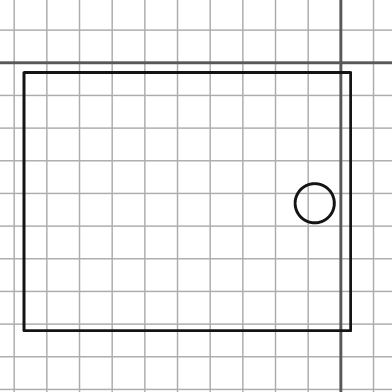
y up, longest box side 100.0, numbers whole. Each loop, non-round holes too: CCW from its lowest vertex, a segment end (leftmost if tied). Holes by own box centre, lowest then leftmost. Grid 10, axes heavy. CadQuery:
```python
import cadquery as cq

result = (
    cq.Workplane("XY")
    .moveTo(-97.0, -82.0)
    .lineTo(3.0, -82.0)
    .lineTo(3.0, -3.0)
    .lineTo(-97.0, -3.0)
    .close()
    .moveTo(-8.0, -43.0)
    .circle(6.0)
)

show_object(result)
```